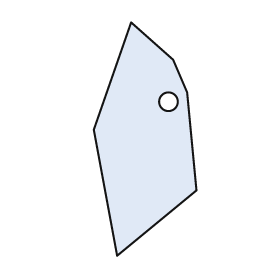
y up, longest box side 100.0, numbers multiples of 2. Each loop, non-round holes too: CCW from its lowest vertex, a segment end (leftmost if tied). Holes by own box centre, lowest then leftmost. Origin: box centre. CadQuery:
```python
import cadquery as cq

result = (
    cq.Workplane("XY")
    .moveTo(-12.0, -50.0)
    .lineTo(22.0, -22.0)
    .lineTo(18.0, 20.0)
    .lineTo(12.0, 34.0)
    .lineTo(-6.0, 50.0)
    .lineTo(-22.0, 4.0)
    .close()
    .moveTo(10.0, 16.0)
    .circle(4.0)
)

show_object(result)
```